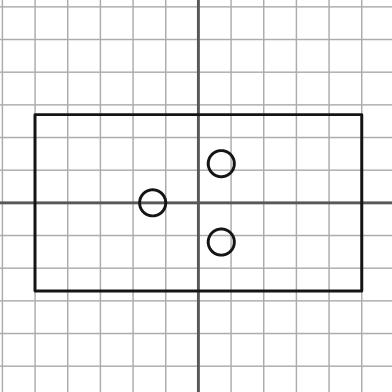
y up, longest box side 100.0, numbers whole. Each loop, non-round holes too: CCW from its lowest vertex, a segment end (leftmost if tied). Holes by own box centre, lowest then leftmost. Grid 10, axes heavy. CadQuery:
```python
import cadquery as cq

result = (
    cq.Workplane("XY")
    .moveTo(-50.0, -27.0)
    .lineTo(50.0, -27.0)
    .lineTo(50.0, 27.0)
    .lineTo(-50.0, 27.0)
    .close()
    .moveTo(7.0, -12.0)
    .circle(4.0)
    .moveTo(-14.0, 0.0)
    .circle(4.0)
    .moveTo(7.0, 12.0)
    .circle(4.0)
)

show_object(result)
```